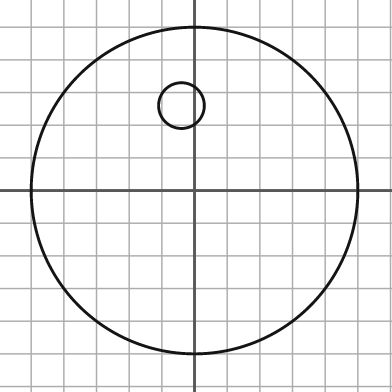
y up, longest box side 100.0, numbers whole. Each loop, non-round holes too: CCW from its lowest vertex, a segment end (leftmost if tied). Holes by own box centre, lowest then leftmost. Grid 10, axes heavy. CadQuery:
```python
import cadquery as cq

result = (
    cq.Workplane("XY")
    .moveTo(0.0, 0.0)
    .circle(50.0)
    .moveTo(-4.0, 26.0)
    .circle(7.0)
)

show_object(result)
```